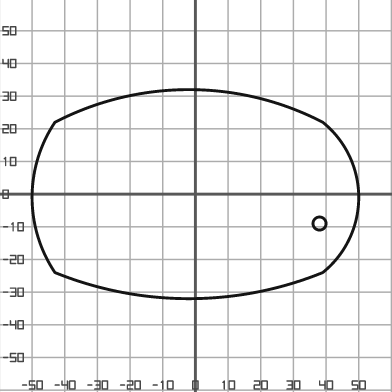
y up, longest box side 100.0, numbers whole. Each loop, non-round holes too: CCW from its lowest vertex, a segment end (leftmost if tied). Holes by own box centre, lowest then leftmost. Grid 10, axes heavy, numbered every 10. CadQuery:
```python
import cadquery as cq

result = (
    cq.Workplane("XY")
    .moveTo(-43.0, -24.0)
    .threePointArc((-2.0, -32.0), (39.0, -24.0))
    .threePointArc((50.0, -1.0), (39.0, 22.0))
    .threePointArc((-2.0, 32.0), (-43.0, 22.0))
    .threePointArc((-50.0, -1.0), (-43.0, -24.0))
    .close()
    .moveTo(38.0, -9.0)
    .circle(2.0)
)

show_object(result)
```